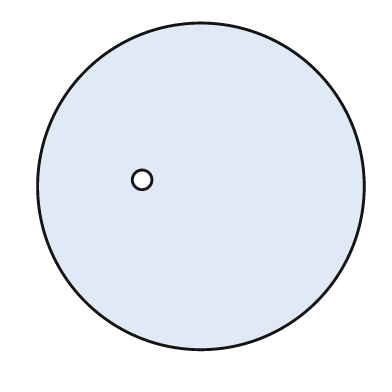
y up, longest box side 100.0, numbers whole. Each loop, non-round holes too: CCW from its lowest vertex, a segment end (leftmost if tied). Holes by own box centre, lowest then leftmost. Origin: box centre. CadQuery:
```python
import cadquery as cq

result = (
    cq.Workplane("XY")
    .moveTo(0.0, 0.0)
    .circle(50.0)
    .moveTo(-18.0, 2.0)
    .circle(3.0)
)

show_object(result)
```